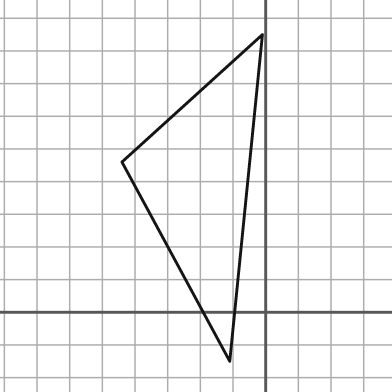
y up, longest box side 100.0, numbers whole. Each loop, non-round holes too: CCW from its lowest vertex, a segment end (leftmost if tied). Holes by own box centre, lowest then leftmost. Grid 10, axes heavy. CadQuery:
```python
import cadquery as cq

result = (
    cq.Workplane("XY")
    .moveTo(-11.0, -15.0)
    .lineTo(-1.0, 85.0)
    .lineTo(-44.0, 46.0)
    .close()
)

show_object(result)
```